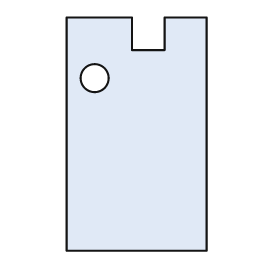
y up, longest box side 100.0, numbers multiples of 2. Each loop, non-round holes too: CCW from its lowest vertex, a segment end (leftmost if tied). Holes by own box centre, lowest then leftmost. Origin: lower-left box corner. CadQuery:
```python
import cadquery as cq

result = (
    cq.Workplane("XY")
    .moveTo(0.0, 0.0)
    .lineTo(60.0, 0.0)
    .lineTo(60.0, 100.0)
    .lineTo(42.0, 100.0)
    .lineTo(42.0, 86.0)
    .lineTo(28.0, 86.0)
    .lineTo(28.0, 100.0)
    .lineTo(0.0, 100.0)
    .close()
    .moveTo(12.0, 74.0)
    .circle(6.0)
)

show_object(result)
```